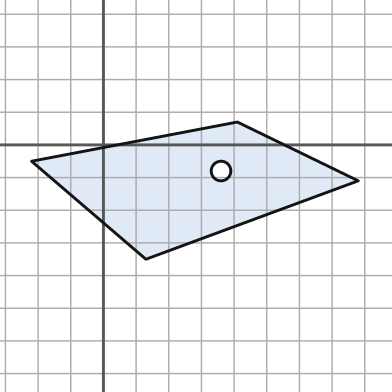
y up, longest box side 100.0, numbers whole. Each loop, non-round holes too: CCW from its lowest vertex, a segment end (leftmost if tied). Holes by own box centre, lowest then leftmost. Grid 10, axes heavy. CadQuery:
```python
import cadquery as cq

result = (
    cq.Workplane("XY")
    .moveTo(13.0, -35.0)
    .lineTo(78.0, -11.0)
    .lineTo(41.0, 7.0)
    .lineTo(-22.0, -5.0)
    .close()
    .moveTo(36.0, -8.0)
    .circle(3.0)
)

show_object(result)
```